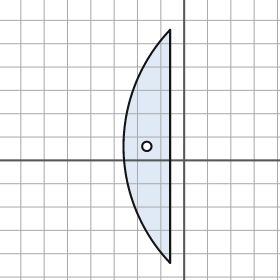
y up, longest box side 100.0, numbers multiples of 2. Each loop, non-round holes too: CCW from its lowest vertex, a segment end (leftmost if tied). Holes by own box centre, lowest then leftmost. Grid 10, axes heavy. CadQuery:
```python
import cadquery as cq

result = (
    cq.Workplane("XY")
    .moveTo(-6.0, -44.0)
    .lineTo(-6.0, 56.0)
    .threePointArc((-26.0, 6.0), (-6.0, -44.0))
    .close()
    .moveTo(-16.0, 6.0)
    .circle(2.0)
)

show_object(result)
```